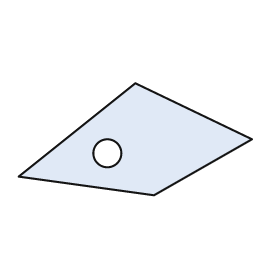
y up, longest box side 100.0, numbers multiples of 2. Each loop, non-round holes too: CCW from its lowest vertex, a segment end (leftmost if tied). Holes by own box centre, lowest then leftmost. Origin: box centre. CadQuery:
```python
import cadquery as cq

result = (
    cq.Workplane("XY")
    .moveTo(8.0, -24.0)
    .lineTo(50.0, 0.0)
    .lineTo(0.0, 24.0)
    .lineTo(-50.0, -16.0)
    .close()
    .moveTo(-12.0, -6.0)
    .circle(6.0)
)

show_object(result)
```